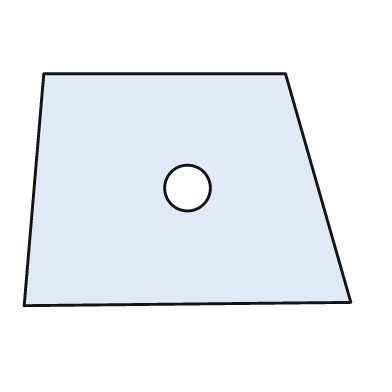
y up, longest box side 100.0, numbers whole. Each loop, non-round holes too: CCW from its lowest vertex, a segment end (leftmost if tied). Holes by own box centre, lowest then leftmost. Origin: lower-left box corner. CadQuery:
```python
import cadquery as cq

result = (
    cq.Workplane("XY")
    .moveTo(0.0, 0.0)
    .lineTo(100.0, 1.0)
    .lineTo(80.0, 71.0)
    .lineTo(6.0, 71.0)
    .close()
    .moveTo(50.0, 36.0)
    .circle(7.0)
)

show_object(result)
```